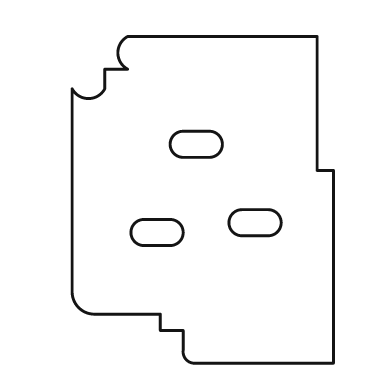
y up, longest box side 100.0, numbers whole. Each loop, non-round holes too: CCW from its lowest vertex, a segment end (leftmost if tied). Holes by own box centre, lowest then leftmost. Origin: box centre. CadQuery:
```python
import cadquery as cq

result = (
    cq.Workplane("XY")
    .moveTo(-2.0, -50.0)
    .lineTo(40.0, -50.0)
    .lineTo(40.0, 9.0)
    .lineTo(35.0, 9.0)
    .lineTo(35.0, 50.0)
    .lineTo(-23.0, 50.0)
    .threePointArc((-26.0, 45.0), (-23.0, 40.0))
    .lineTo(-30.0, 40.0)
    .lineTo(-30.0, 34.0)
    .threePointArc((-35.0, 31.0), (-40.0, 34.0))
    .lineTo(-40.0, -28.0)
    .threePointArc((-38.0, -33.0), (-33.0, -35.0))
    .lineTo(-13.0, -35.0)
    .lineTo(-13.0, -40.0)
    .lineTo(-6.0, -40.0)
    .lineTo(-6.0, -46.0)
    .threePointArc((-5.0, -49.0), (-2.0, -50.0))
    .close()
    .moveTo(-18.0, -14.0)
    .lineTo(-10.0, -14.0)
    .threePointArc((-6.0, -10.0), (-10.0, -6.0))
    .lineTo(-18.0, -6.0)
    .threePointArc((-22.0, -10.0), (-18.0, -14.0))
    .close()
    .moveTo(12.0, -11.0)
    .lineTo(20.0, -11.0)
    .threePointArc((24.0, -7.0), (20.0, -3.0))
    .lineTo(12.0, -3.0)
    .threePointArc((8.0, -7.0), (12.0, -11.0))
    .close()
    .moveTo(-6.0, 13.0)
    .lineTo(2.0, 13.0)
    .threePointArc((6.0, 17.0), (2.0, 21.0))
    .lineTo(-6.0, 21.0)
    .threePointArc((-10.0, 17.0), (-6.0, 13.0))
    .close()
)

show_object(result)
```